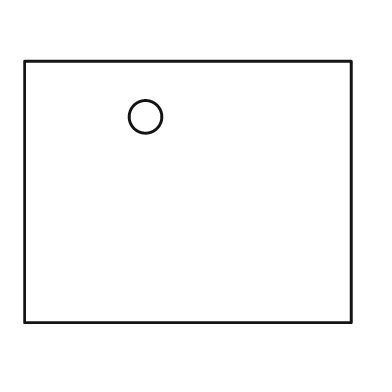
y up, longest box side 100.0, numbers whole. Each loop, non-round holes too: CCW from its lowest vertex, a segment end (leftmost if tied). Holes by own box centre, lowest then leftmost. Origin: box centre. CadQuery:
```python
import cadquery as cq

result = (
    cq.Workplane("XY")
    .moveTo(-50.0, -40.0)
    .lineTo(50.0, -40.0)
    .lineTo(50.0, 40.0)
    .lineTo(-50.0, 40.0)
    .close()
    .moveTo(-13.0, 23.0)
    .circle(5.0)
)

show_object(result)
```